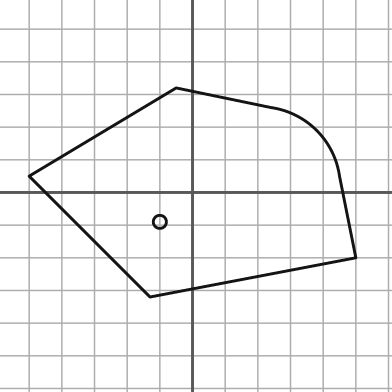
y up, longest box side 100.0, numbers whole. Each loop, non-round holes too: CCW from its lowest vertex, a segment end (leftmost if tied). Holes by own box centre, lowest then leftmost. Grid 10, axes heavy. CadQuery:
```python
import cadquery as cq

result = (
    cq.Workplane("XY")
    .moveTo(-13.0, -32.0)
    .lineTo(50.0, -20.0)
    .lineTo(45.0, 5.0)
    .threePointArc((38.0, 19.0), (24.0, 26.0))
    .lineTo(-5.0, 32.0)
    .lineTo(-50.0, 5.0)
    .close()
    .moveTo(-10.0, -9.0)
    .circle(2.0)
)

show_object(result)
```